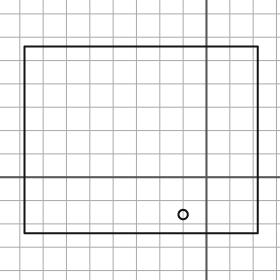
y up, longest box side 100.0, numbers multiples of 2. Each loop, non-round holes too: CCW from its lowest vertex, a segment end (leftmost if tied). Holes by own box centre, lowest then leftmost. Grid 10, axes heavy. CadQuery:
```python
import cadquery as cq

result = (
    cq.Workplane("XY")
    .moveTo(-78.0, -24.0)
    .lineTo(22.0, -24.0)
    .lineTo(22.0, 56.0)
    .lineTo(-78.0, 56.0)
    .close()
    .moveTo(-10.0, -16.0)
    .circle(2.0)
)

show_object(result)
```